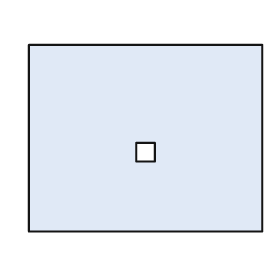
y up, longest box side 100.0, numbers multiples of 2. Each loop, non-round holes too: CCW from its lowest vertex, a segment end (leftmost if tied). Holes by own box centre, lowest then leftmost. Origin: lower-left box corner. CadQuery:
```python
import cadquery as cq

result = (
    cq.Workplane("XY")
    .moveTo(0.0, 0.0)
    .lineTo(100.0, 0.0)
    .lineTo(100.0, 80.0)
    .lineTo(0.0, 80.0)
    .close()
    .moveTo(46.0, 30.0)
    .lineTo(54.0, 30.0)
    .lineTo(54.0, 38.0)
    .lineTo(46.0, 38.0)
    .close()
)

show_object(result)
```